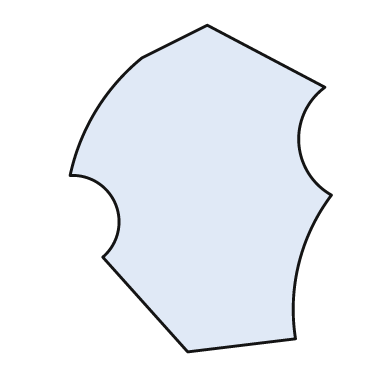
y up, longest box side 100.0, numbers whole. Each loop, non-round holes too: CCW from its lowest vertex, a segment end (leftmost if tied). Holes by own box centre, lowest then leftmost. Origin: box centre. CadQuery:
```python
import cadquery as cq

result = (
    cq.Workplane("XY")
    .moveTo(-4.0, -50.0)
    .lineTo(29.0, -46.0)
    .threePointArc((30.0, -23.0), (40.0, -2.0))
    .threePointArc((30.0, 14.0), (38.0, 31.0))
    .lineTo(2.0, 50.0)
    .lineTo(-18.0, 40.0)
    .threePointArc((-32.0, 24.0), (-40.0, 4.0))
    .threePointArc((-26.0, -5.0), (-30.0, -21.0))
    .close()
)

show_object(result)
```